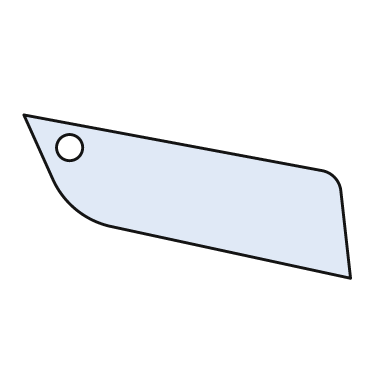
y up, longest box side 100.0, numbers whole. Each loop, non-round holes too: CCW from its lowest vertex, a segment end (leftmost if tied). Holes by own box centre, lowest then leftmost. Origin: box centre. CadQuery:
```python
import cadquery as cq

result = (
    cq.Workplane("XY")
    .moveTo(50.0, -25.0)
    .lineTo(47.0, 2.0)
    .threePointArc((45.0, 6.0), (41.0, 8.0))
    .lineTo(-50.0, 25.0)
    .lineTo(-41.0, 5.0)
    .threePointArc((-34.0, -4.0), (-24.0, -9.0))
    .close()
    .moveTo(-36.0, 15.0)
    .circle(4.0)
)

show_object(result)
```